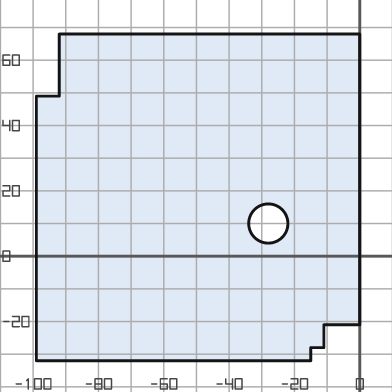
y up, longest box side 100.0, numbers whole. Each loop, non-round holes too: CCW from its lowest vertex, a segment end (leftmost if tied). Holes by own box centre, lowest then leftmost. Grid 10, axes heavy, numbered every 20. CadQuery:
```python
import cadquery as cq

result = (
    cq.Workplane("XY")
    .moveTo(-99.0, -32.0)
    .lineTo(-15.0, -32.0)
    .lineTo(-15.0, -28.0)
    .lineTo(-11.0, -28.0)
    .lineTo(-11.0, -21.0)
    .lineTo(0.0, -21.0)
    .lineTo(0.0, 68.0)
    .lineTo(-92.0, 68.0)
    .lineTo(-92.0, 49.0)
    .lineTo(-99.0, 49.0)
    .close()
    .moveTo(-28.0, 10.0)
    .circle(6.0)
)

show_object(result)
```